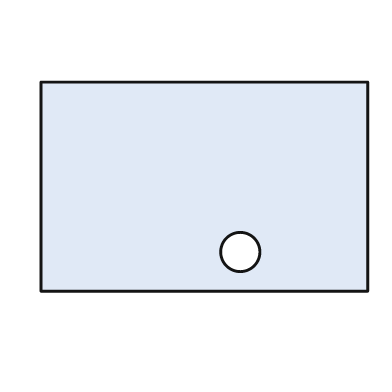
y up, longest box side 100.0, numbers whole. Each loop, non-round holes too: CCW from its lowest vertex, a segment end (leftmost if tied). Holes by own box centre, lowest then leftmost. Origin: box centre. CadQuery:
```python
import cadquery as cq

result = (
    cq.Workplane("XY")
    .moveTo(-50.0, -32.0)
    .lineTo(50.0, -32.0)
    .lineTo(50.0, 32.0)
    .lineTo(-50.0, 32.0)
    .close()
    .moveTo(11.0, -20.0)
    .circle(6.0)
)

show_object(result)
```